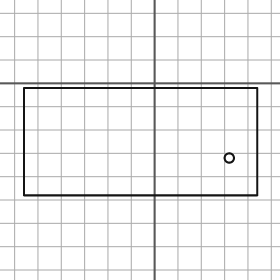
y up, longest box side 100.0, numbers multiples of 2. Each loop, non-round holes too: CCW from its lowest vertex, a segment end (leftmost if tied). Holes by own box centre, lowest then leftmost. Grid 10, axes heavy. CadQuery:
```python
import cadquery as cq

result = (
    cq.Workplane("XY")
    .moveTo(-56.0, -48.0)
    .lineTo(44.0, -48.0)
    .lineTo(44.0, -2.0)
    .lineTo(-56.0, -2.0)
    .close()
    .moveTo(32.0, -32.0)
    .circle(2.0)
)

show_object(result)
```